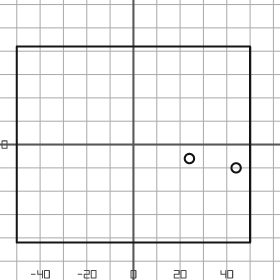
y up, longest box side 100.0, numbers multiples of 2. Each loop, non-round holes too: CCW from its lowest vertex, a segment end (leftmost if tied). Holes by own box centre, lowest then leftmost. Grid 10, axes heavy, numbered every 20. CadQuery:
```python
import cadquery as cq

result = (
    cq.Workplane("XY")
    .moveTo(-50.0, -42.0)
    .lineTo(50.0, -42.0)
    .lineTo(50.0, 42.0)
    .lineTo(-50.0, 42.0)
    .close()
    .moveTo(44.0, -10.0)
    .circle(2.0)
    .moveTo(24.0, -6.0)
    .circle(2.0)
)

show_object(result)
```